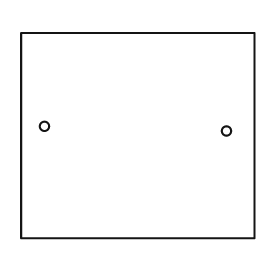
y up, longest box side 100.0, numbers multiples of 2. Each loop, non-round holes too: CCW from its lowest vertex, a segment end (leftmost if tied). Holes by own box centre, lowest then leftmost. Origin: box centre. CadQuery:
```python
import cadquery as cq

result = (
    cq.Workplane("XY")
    .moveTo(-50.0, -44.0)
    .lineTo(50.0, -44.0)
    .lineTo(50.0, 44.0)
    .lineTo(-50.0, 44.0)
    .close()
    .moveTo(38.0, 2.0)
    .circle(2.0)
    .moveTo(-40.0, 4.0)
    .circle(2.0)
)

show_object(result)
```